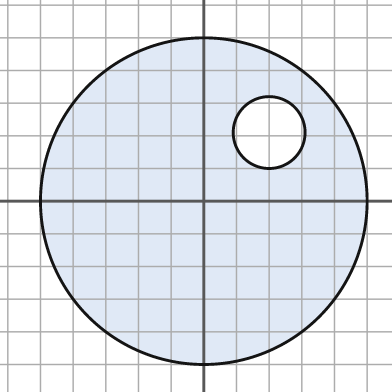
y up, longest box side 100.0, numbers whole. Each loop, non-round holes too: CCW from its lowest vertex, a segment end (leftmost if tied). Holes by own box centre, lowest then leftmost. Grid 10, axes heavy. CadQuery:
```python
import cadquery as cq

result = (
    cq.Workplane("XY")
    .moveTo(0.0, 0.0)
    .circle(50.0)
    .moveTo(20.0, 21.0)
    .circle(11.0)
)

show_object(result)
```